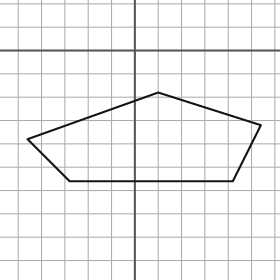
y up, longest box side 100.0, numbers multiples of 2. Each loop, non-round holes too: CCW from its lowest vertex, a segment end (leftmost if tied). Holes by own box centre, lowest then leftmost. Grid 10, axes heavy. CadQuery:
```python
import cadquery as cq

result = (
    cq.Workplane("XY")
    .moveTo(-28.0, -56.0)
    .lineTo(42.0, -56.0)
    .lineTo(54.0, -32.0)
    .lineTo(10.0, -18.0)
    .lineTo(-46.0, -38.0)
    .close()
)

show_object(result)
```